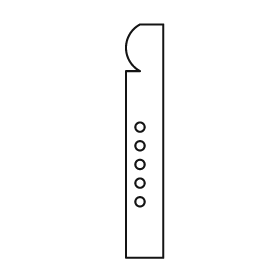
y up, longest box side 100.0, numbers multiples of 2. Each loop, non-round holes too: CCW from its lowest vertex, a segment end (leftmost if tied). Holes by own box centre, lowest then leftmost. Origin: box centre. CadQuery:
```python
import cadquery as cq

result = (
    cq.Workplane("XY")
    .moveTo(-8.0, -50.0)
    .lineTo(8.0, -50.0)
    .lineTo(8.0, 50.0)
    .lineTo(-2.0, 50.0)
    .threePointArc((-8.0, 40.0), (-2.0, 30.0))
    .lineTo(-8.0, 30.0)
    .close()
    .moveTo(-2.0, -26.0)
    .circle(2.0)
    .moveTo(-2.0, -18.0)
    .circle(2.0)
    .moveTo(-2.0, -10.0)
    .circle(2.0)
    .moveTo(-2.0, -2.0)
    .circle(2.0)
    .moveTo(-2.0, 6.0)
    .circle(2.0)
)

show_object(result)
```